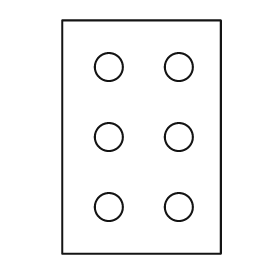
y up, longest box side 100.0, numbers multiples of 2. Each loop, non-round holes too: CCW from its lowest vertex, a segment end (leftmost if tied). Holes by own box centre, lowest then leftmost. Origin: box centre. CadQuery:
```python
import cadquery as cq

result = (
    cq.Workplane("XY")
    .moveTo(-34.0, -50.0)
    .lineTo(34.0, -50.0)
    .lineTo(34.0, 50.0)
    .lineTo(-34.0, 50.0)
    .close()
    .moveTo(-14.0, -30.0)
    .circle(6.0)
    .moveTo(16.0, -30.0)
    .circle(6.0)
    .moveTo(-14.0, 0.0)
    .circle(6.0)
    .moveTo(16.0, 0.0)
    .circle(6.0)
    .moveTo(-14.0, 30.0)
    .circle(6.0)
    .moveTo(16.0, 30.0)
    .circle(6.0)
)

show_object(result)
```